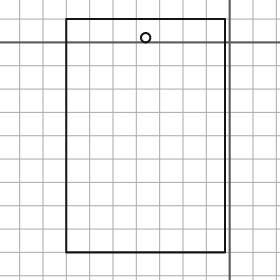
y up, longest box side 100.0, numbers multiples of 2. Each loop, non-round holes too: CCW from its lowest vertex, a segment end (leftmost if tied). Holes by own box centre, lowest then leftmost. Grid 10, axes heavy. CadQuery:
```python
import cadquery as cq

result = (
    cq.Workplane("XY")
    .moveTo(-70.0, -90.0)
    .lineTo(-2.0, -90.0)
    .lineTo(-2.0, 10.0)
    .lineTo(-70.0, 10.0)
    .close()
    .moveTo(-36.0, 2.0)
    .circle(2.0)
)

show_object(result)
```